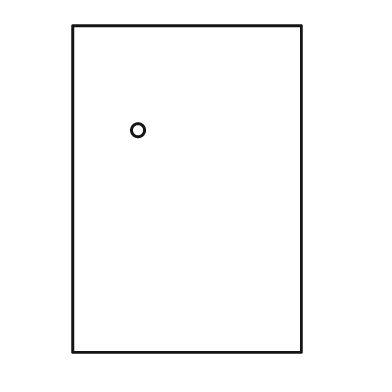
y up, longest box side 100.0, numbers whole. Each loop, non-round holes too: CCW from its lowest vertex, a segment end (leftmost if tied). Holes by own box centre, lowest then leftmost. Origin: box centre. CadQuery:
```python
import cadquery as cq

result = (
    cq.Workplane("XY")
    .moveTo(-35.0, -50.0)
    .lineTo(35.0, -50.0)
    .lineTo(35.0, 50.0)
    .lineTo(-35.0, 50.0)
    .close()
    .moveTo(-15.0, 18.0)
    .circle(2.0)
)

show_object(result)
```